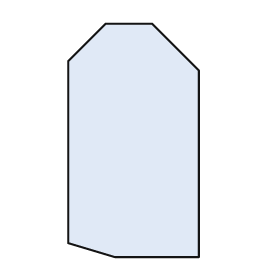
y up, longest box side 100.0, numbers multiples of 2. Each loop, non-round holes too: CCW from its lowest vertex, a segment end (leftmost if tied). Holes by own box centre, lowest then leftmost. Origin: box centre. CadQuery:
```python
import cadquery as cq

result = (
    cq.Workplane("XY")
    .moveTo(-8.0, -50.0)
    .lineTo(28.0, -50.0)
    .lineTo(28.0, 30.0)
    .lineTo(8.0, 50.0)
    .lineTo(-12.0, 50.0)
    .lineTo(-28.0, 34.0)
    .lineTo(-28.0, -44.0)
    .close()
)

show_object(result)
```